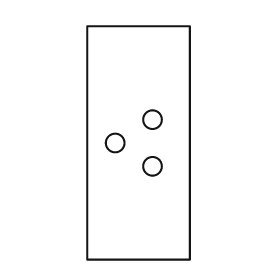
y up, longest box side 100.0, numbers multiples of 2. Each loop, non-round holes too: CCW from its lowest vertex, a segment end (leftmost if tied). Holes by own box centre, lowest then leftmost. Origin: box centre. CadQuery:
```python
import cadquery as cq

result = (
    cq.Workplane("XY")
    .moveTo(-22.0, -50.0)
    .lineTo(22.0, -50.0)
    .lineTo(22.0, 50.0)
    .lineTo(-22.0, 50.0)
    .close()
    .moveTo(6.0, -10.0)
    .circle(4.0)
    .moveTo(-10.0, 0.0)
    .circle(4.0)
    .moveTo(6.0, 10.0)
    .circle(4.0)
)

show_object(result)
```